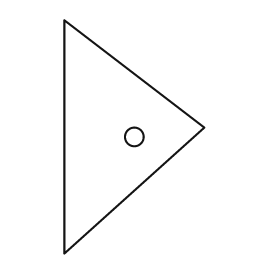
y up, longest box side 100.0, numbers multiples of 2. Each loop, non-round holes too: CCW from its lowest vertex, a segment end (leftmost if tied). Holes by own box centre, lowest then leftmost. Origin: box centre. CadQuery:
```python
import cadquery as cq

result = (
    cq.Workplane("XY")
    .moveTo(-30.0, -50.0)
    .lineTo(30.0, 4.0)
    .lineTo(-30.0, 50.0)
    .close()
    .moveTo(0.0, 0.0)
    .circle(4.0)
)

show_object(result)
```